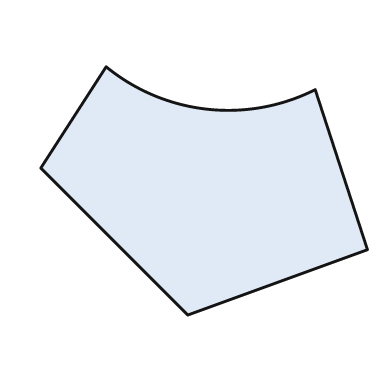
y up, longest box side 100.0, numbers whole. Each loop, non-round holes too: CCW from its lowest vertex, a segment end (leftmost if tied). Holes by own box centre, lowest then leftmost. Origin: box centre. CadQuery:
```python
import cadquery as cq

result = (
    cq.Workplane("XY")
    .moveTo(-5.0, -38.0)
    .lineTo(50.0, -18.0)
    .lineTo(34.0, 31.0)
    .threePointArc((1.0, 25.0), (-30.0, 38.0))
    .lineTo(-50.0, 7.0)
    .close()
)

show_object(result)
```